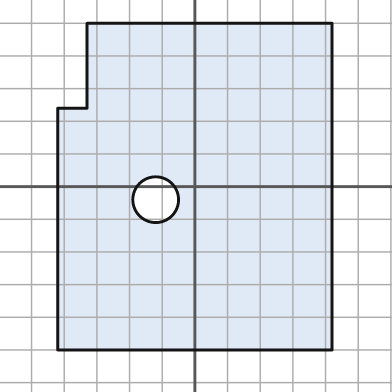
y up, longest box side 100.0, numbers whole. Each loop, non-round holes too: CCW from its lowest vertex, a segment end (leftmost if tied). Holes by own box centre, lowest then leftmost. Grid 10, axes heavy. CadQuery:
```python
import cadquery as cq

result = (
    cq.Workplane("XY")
    .moveTo(-42.0, -50.0)
    .lineTo(42.0, -50.0)
    .lineTo(42.0, 50.0)
    .lineTo(-33.0, 50.0)
    .lineTo(-33.0, 24.0)
    .lineTo(-42.0, 24.0)
    .close()
    .moveTo(-12.0, -4.0)
    .circle(7.0)
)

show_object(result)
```